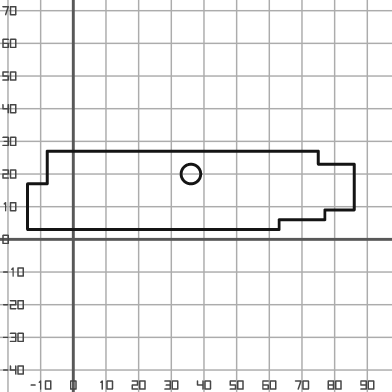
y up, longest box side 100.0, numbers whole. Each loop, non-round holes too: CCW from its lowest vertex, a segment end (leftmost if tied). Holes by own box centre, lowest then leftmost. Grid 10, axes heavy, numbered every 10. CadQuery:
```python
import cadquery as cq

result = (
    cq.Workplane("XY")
    .moveTo(-14.0, 3.0)
    .lineTo(63.0, 3.0)
    .lineTo(63.0, 6.0)
    .lineTo(77.0, 6.0)
    .lineTo(77.0, 9.0)
    .lineTo(86.0, 9.0)
    .lineTo(86.0, 23.0)
    .lineTo(75.0, 23.0)
    .lineTo(75.0, 27.0)
    .lineTo(-8.0, 27.0)
    .lineTo(-8.0, 17.0)
    .lineTo(-14.0, 17.0)
    .close()
    .moveTo(36.0, 20.0)
    .circle(3.0)
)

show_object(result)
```